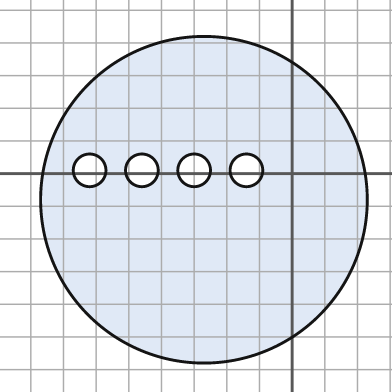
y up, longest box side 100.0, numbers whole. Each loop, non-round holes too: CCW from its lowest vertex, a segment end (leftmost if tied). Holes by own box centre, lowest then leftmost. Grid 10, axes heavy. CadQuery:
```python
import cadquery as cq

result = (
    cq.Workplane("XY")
    .moveTo(-27.0, -8.0)
    .circle(50.0)
    .moveTo(-62.0, 1.0)
    .circle(5.0)
    .moveTo(-46.0, 1.0)
    .circle(5.0)
    .moveTo(-30.0, 1.0)
    .circle(5.0)
    .moveTo(-14.0, 1.0)
    .circle(5.0)
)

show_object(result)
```